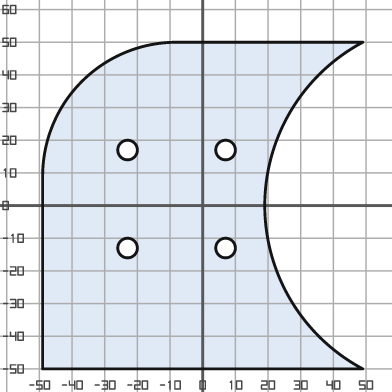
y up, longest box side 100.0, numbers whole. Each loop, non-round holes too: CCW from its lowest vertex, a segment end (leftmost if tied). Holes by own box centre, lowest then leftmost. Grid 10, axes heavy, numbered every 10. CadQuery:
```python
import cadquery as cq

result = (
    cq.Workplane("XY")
    .moveTo(-49.0, -50.0)
    .lineTo(49.0, -50.0)
    .threePointArc((19.0, 0.0), (49.0, 50.0))
    .lineTo(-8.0, 50.0)
    .threePointArc((-37.0, 38.0), (-49.0, 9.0))
    .close()
    .moveTo(-23.0, -13.0)
    .circle(3.0)
    .moveTo(7.0, -13.0)
    .circle(3.0)
    .moveTo(-23.0, 17.0)
    .circle(3.0)
    .moveTo(7.0, 17.0)
    .circle(3.0)
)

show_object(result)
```